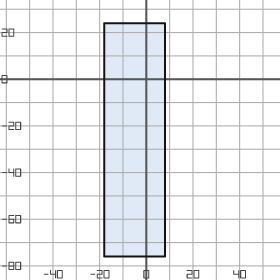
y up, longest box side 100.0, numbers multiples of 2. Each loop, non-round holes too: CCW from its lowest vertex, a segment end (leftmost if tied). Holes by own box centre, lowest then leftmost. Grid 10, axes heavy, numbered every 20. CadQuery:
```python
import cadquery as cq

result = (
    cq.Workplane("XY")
    .moveTo(-18.0, -76.0)
    .lineTo(8.0, -76.0)
    .lineTo(8.0, 24.0)
    .lineTo(-18.0, 24.0)
    .close()
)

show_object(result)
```